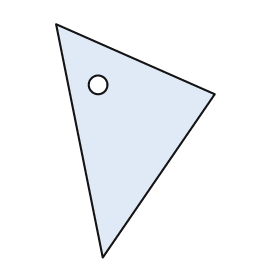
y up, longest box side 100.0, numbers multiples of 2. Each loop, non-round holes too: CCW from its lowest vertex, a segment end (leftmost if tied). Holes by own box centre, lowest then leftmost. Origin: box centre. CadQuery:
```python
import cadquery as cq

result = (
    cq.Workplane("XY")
    .moveTo(-14.0, -50.0)
    .lineTo(34.0, 20.0)
    .lineTo(-34.0, 50.0)
    .close()
    .moveTo(-16.0, 24.0)
    .circle(4.0)
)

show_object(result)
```